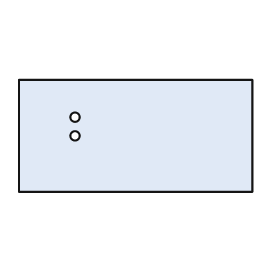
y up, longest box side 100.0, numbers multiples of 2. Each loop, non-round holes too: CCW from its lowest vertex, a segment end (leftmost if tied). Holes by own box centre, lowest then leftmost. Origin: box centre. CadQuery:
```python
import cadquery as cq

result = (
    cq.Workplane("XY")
    .moveTo(-50.0, -24.0)
    .lineTo(50.0, -24.0)
    .lineTo(50.0, 24.0)
    .lineTo(-50.0, 24.0)
    .close()
    .moveTo(-26.0, 0.0)
    .circle(2.0)
    .moveTo(-26.0, 8.0)
    .circle(2.0)
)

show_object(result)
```